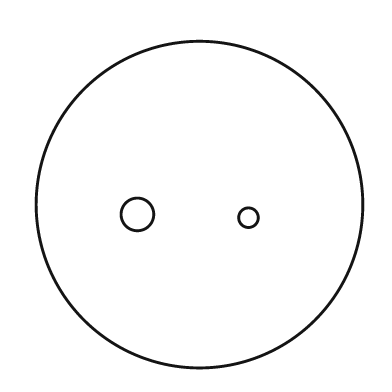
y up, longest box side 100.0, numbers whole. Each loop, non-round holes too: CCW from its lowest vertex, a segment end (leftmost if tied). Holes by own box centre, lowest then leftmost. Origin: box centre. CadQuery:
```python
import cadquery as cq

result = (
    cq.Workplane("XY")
    .moveTo(0.0, 0.0)
    .circle(50.0)
    .moveTo(15.0, -4.0)
    .circle(3.0)
    .moveTo(-19.0, -3.0)
    .circle(5.0)
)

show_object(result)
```